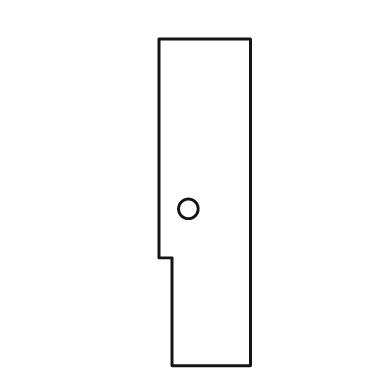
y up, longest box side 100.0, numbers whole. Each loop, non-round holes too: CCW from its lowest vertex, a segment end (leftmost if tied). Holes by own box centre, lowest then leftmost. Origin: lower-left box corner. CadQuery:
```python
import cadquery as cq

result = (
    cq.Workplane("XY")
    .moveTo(4.0, 0.0)
    .lineTo(28.0, 0.0)
    .lineTo(28.0, 100.0)
    .lineTo(0.0, 100.0)
    .lineTo(0.0, 33.0)
    .lineTo(4.0, 33.0)
    .close()
    .moveTo(9.0, 48.0)
    .circle(3.0)
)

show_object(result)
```